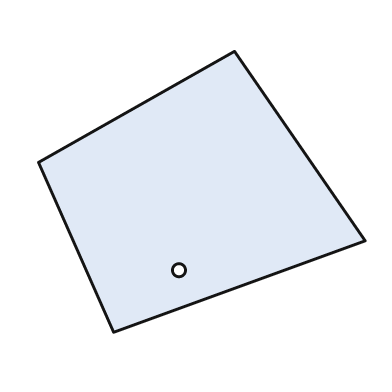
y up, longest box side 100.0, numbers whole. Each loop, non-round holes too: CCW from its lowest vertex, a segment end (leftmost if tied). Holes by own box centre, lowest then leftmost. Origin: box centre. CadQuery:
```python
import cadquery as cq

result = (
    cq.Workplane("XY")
    .moveTo(-27.0, -43.0)
    .lineTo(50.0, -15.0)
    .lineTo(10.0, 43.0)
    .lineTo(-50.0, 9.0)
    .close()
    .moveTo(-7.0, -24.0)
    .circle(2.0)
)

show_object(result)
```